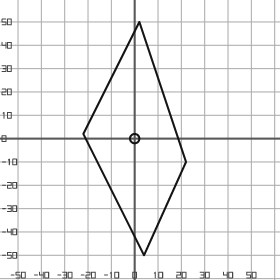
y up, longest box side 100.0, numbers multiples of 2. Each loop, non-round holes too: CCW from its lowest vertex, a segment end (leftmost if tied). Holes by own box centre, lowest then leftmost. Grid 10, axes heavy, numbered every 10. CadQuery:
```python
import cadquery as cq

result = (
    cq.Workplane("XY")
    .moveTo(4.0, -50.0)
    .lineTo(22.0, -10.0)
    .lineTo(2.0, 50.0)
    .lineTo(-22.0, 2.0)
    .close()
    .moveTo(0.0, 0.0)
    .circle(2.0)
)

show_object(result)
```